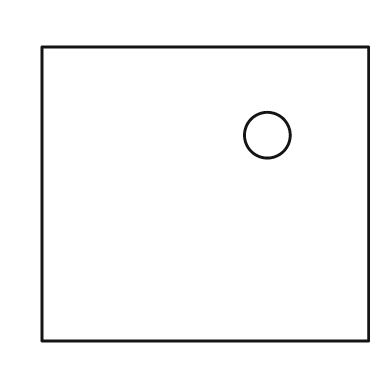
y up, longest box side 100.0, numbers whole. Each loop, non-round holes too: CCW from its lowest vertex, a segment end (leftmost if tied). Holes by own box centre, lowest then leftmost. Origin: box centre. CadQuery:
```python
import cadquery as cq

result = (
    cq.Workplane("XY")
    .moveTo(-50.0, -45.0)
    .lineTo(50.0, -45.0)
    .lineTo(50.0, 45.0)
    .lineTo(-50.0, 45.0)
    .close()
    .moveTo(19.0, 18.0)
    .circle(7.0)
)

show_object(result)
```